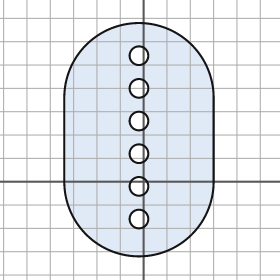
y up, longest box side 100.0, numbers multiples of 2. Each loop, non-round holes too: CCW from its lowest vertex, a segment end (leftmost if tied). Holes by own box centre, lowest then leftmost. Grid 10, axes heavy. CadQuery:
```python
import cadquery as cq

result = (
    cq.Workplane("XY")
    .moveTo(-34.0, 0.0)
    .threePointArc((-2.0, -32.0), (30.0, 0.0))
    .lineTo(30.0, 36.0)
    .threePointArc((-2.0, 68.0), (-34.0, 36.0))
    .close()
    .moveTo(-2.0, -16.0)
    .circle(4.0)
    .moveTo(-2.0, -2.0)
    .circle(4.0)
    .moveTo(-2.0, 12.0)
    .circle(4.0)
    .moveTo(-2.0, 26.0)
    .circle(4.0)
    .moveTo(-2.0, 40.0)
    .circle(4.0)
    .moveTo(-2.0, 54.0)
    .circle(4.0)
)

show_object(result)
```